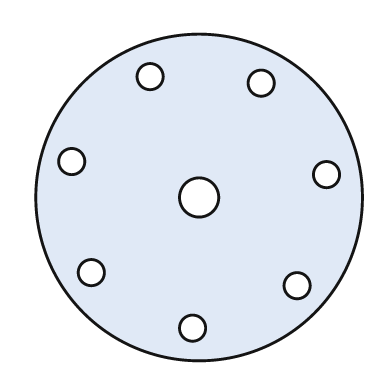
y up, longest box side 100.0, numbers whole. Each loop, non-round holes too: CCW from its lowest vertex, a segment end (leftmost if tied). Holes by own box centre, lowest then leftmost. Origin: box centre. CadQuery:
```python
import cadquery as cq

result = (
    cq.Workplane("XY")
    .moveTo(0.0, 0.0)
    .circle(50.0)
    .moveTo(-2.0, -40.0)
    .circle(4.0)
    .moveTo(30.0, -27.0)
    .circle(4.0)
    .moveTo(-33.0, -23.0)
    .circle(4.0)
    .moveTo(0.0, 0.0)
    .circle(6.0)
    .moveTo(39.0, 7.0)
    .circle(4.0)
    .moveTo(-39.0, 11.0)
    .circle(4.0)
    .moveTo(19.0, 35.0)
    .circle(4.0)
    .moveTo(-15.0, 37.0)
    .circle(4.0)
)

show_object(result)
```